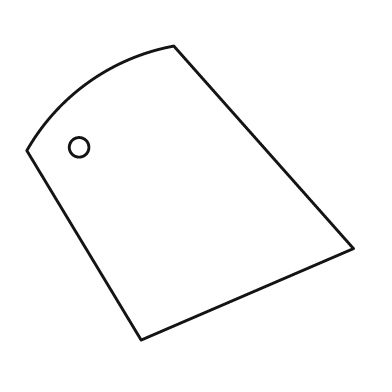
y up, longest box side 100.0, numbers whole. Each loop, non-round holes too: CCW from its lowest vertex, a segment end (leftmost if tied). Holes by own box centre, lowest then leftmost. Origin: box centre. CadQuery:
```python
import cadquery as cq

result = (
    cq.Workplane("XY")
    .moveTo(-15.0, -45.0)
    .lineTo(50.0, -17.0)
    .lineTo(-5.0, 45.0)
    .threePointArc((-31.0, 34.0), (-50.0, 13.0))
    .close()
    .moveTo(-34.0, 14.0)
    .circle(3.0)
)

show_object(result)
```